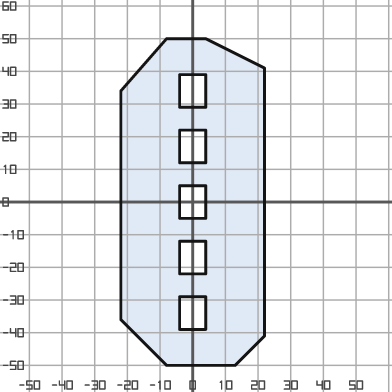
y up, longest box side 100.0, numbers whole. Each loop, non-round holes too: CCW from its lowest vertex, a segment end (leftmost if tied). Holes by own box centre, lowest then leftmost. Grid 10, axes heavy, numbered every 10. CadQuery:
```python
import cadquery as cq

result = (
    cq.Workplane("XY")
    .moveTo(-8.0, -50.0)
    .lineTo(13.0, -50.0)
    .lineTo(22.0, -41.0)
    .lineTo(22.0, 41.0)
    .lineTo(4.0, 50.0)
    .lineTo(-8.0, 50.0)
    .lineTo(-22.0, 34.0)
    .lineTo(-22.0, -36.0)
    .close()
    .moveTo(-4.0, -39.0)
    .lineTo(4.0, -39.0)
    .lineTo(4.0, -29.0)
    .lineTo(-4.0, -29.0)
    .close()
    .moveTo(-4.0, -22.0)
    .lineTo(4.0, -22.0)
    .lineTo(4.0, -12.0)
    .lineTo(-4.0, -12.0)
    .close()
    .moveTo(-4.0, -5.0)
    .lineTo(4.0, -5.0)
    .lineTo(4.0, 5.0)
    .lineTo(-4.0, 5.0)
    .close()
    .moveTo(-4.0, 12.0)
    .lineTo(4.0, 12.0)
    .lineTo(4.0, 22.0)
    .lineTo(-4.0, 22.0)
    .close()
    .moveTo(-4.0, 29.0)
    .lineTo(4.0, 29.0)
    .lineTo(4.0, 39.0)
    .lineTo(-4.0, 39.0)
    .close()
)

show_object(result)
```